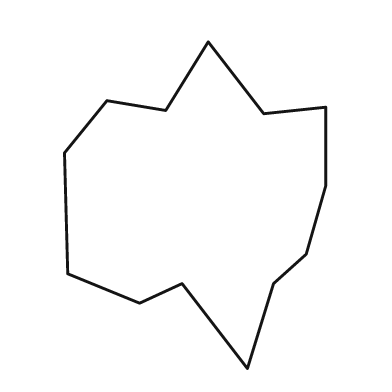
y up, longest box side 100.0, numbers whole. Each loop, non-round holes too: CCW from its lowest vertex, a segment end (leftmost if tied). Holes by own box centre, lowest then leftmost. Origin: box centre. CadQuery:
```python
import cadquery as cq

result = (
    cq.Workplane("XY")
    .moveTo(16.0, -50.0)
    .lineTo(24.0, -24.0)
    .lineTo(34.0, -15.0)
    .lineTo(40.0, 6.0)
    .lineTo(40.0, 30.0)
    .lineTo(21.0, 28.0)
    .lineTo(4.0, 50.0)
    .lineTo(-9.0, 29.0)
    .lineTo(-27.0, 32.0)
    .lineTo(-40.0, 16.0)
    .lineTo(-39.0, -21.0)
    .lineTo(-17.0, -30.0)
    .lineTo(-4.0, -24.0)
    .close()
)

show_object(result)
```